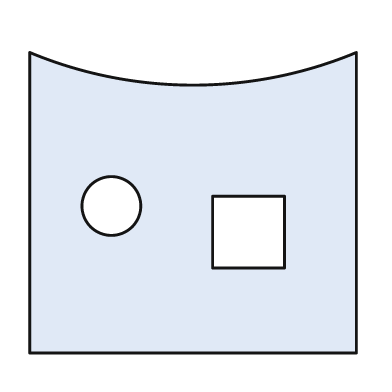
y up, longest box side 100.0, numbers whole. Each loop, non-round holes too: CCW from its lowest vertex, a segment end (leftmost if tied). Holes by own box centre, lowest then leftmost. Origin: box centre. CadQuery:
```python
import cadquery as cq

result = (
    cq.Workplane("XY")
    .moveTo(-50.0, -46.0)
    .lineTo(50.0, -46.0)
    .lineTo(50.0, 46.0)
    .threePointArc((0.0, 36.0), (-50.0, 46.0))
    .close()
    .moveTo(6.0, -20.0)
    .lineTo(28.0, -20.0)
    .lineTo(28.0, 2.0)
    .lineTo(6.0, 2.0)
    .close()
    .moveTo(-25.0, -1.0)
    .circle(9.0)
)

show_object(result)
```